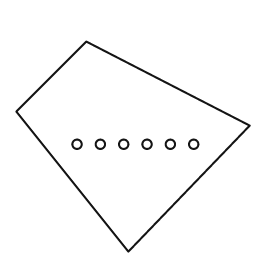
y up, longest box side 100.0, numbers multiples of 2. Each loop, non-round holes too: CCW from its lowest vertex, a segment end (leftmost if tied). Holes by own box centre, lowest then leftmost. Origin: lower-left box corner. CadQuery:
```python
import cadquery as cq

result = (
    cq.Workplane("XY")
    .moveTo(48.0, 0.0)
    .lineTo(100.0, 54.0)
    .lineTo(30.0, 90.0)
    .lineTo(0.0, 60.0)
    .close()
    .moveTo(26.0, 46.0)
    .circle(2.0)
    .moveTo(36.0, 46.0)
    .circle(2.0)
    .moveTo(46.0, 46.0)
    .circle(2.0)
    .moveTo(56.0, 46.0)
    .circle(2.0)
    .moveTo(66.0, 46.0)
    .circle(2.0)
    .moveTo(76.0, 46.0)
    .circle(2.0)
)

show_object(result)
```